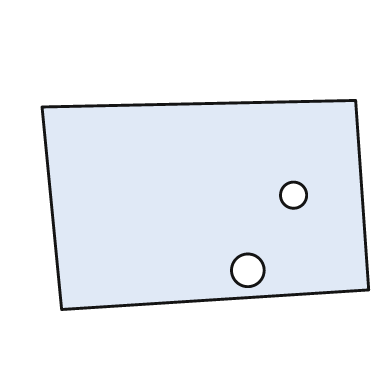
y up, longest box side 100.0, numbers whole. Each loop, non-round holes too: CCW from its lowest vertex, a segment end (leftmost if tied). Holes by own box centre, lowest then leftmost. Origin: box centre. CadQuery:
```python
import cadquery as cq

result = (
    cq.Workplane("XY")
    .moveTo(-44.0, -32.0)
    .lineTo(50.0, -26.0)
    .lineTo(46.0, 32.0)
    .lineTo(-50.0, 30.0)
    .close()
    .moveTo(13.0, -20.0)
    .circle(5.0)
    .moveTo(27.0, 3.0)
    .circle(4.0)
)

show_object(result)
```